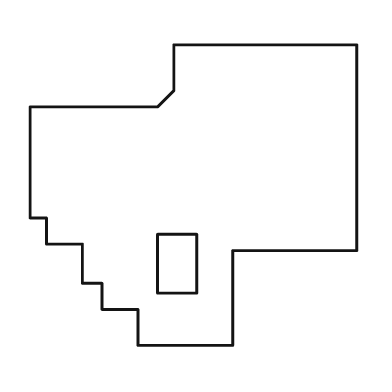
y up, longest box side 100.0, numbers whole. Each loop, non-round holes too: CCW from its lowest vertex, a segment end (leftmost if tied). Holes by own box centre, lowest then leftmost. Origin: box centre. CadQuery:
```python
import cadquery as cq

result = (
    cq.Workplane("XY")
    .moveTo(-17.0, -46.0)
    .lineTo(12.0, -46.0)
    .lineTo(12.0, -17.0)
    .lineTo(50.0, -17.0)
    .lineTo(50.0, 46.0)
    .lineTo(-6.0, 46.0)
    .lineTo(-6.0, 32.0)
    .lineTo(-11.0, 27.0)
    .lineTo(-50.0, 27.0)
    .lineTo(-50.0, -7.0)
    .lineTo(-45.0, -7.0)
    .lineTo(-45.0, -15.0)
    .lineTo(-34.0, -15.0)
    .lineTo(-34.0, -27.0)
    .lineTo(-28.0, -27.0)
    .lineTo(-28.0, -35.0)
    .lineTo(-17.0, -35.0)
    .close()
    .moveTo(-11.0, -30.0)
    .lineTo(1.0, -30.0)
    .lineTo(1.0, -12.0)
    .lineTo(-11.0, -12.0)
    .close()
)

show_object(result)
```